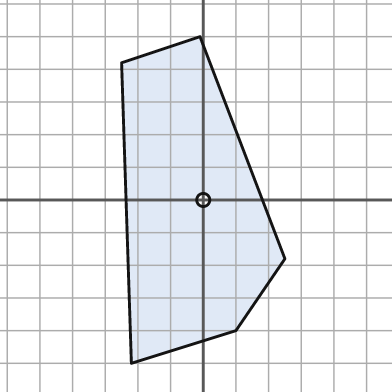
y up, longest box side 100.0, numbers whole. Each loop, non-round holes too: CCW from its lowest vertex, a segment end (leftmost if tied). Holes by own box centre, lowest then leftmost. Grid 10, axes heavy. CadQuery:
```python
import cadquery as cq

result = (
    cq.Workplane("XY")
    .moveTo(-22.0, -50.0)
    .lineTo(10.0, -40.0)
    .lineTo(25.0, -18.0)
    .lineTo(-1.0, 50.0)
    .lineTo(-25.0, 42.0)
    .close()
    .moveTo(0.0, 0.0)
    .circle(2.0)
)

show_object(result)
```